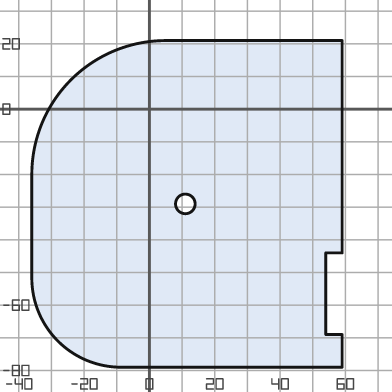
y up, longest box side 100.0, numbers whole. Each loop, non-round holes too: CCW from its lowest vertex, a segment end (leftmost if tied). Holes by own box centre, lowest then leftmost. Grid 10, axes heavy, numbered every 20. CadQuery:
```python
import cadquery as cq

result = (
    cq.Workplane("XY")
    .moveTo(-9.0, -79.0)
    .lineTo(59.0, -79.0)
    .lineTo(59.0, -69.0)
    .lineTo(54.0, -69.0)
    .lineTo(54.0, -44.0)
    .lineTo(59.0, -44.0)
    .lineTo(59.0, 21.0)
    .lineTo(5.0, 21.0)
    .threePointArc((-24.0, 9.0), (-36.0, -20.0))
    .lineTo(-36.0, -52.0)
    .threePointArc((-28.0, -71.0), (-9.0, -79.0))
    .close()
    .moveTo(11.0, -29.0)
    .circle(3.0)
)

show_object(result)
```